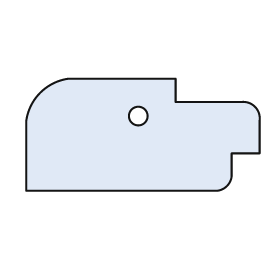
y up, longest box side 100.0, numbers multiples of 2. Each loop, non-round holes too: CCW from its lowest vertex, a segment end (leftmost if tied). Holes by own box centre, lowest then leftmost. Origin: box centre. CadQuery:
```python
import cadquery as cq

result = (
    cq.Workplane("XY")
    .moveTo(-50.0, -24.0)
    .lineTo(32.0, -24.0)
    .threePointArc((36.0, -22.0), (38.0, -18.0))
    .lineTo(38.0, -8.0)
    .lineTo(50.0, -8.0)
    .lineTo(50.0, 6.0)
    .threePointArc((48.0, 12.0), (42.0, 14.0))
    .lineTo(14.0, 14.0)
    .lineTo(14.0, 24.0)
    .lineTo(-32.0, 24.0)
    .threePointArc((-44.0, 18.0), (-50.0, 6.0))
    .close()
    .moveTo(-2.0, 8.0)
    .circle(4.0)
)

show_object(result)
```